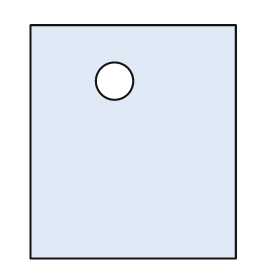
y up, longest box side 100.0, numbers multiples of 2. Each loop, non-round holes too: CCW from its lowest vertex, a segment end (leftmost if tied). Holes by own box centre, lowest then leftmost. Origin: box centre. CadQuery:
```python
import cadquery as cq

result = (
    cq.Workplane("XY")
    .moveTo(-44.0, -50.0)
    .lineTo(44.0, -50.0)
    .lineTo(44.0, 50.0)
    .lineTo(-44.0, 50.0)
    .close()
    .moveTo(-8.0, 26.0)
    .circle(8.0)
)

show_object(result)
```